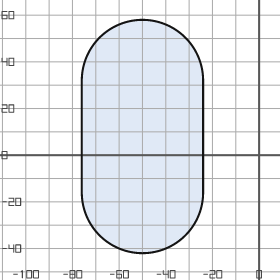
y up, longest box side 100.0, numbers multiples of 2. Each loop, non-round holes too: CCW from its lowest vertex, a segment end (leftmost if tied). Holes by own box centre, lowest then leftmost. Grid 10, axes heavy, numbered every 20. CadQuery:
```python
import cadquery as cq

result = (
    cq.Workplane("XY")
    .moveTo(-76.0, -16.0)
    .threePointArc((-50.0, -42.0), (-24.0, -16.0))
    .lineTo(-24.0, 32.0)
    .threePointArc((-50.0, 58.0), (-76.0, 32.0))
    .close()
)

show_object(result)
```